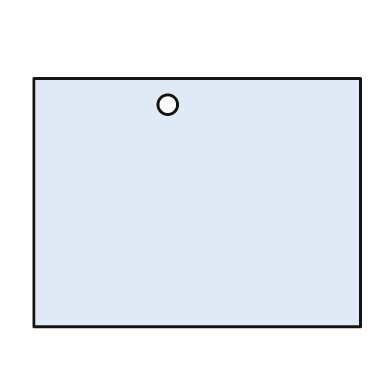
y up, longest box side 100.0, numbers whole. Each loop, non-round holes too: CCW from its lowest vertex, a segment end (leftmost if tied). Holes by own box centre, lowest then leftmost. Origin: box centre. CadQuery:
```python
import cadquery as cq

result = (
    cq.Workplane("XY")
    .moveTo(-50.0, -38.0)
    .lineTo(50.0, -38.0)
    .lineTo(50.0, 38.0)
    .lineTo(-50.0, 38.0)
    .close()
    .moveTo(-9.0, 30.0)
    .circle(3.0)
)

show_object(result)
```